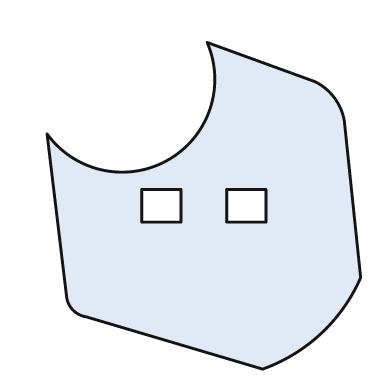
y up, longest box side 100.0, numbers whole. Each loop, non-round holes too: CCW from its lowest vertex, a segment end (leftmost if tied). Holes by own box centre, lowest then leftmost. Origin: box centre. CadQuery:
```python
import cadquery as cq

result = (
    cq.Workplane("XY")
    .moveTo(18.0, -50.0)
    .threePointArc((36.0, -39.0), (48.0, -22.0))
    .lineTo(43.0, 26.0)
    .threePointArc((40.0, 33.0), (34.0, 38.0))
    .lineTo(1.0, 50.0)
    .threePointArc((-11.0, 14.0), (-48.0, 22.0))
    .lineTo(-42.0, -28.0)
    .threePointArc((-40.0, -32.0), (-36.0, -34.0))
    .close()
    .moveTo(-19.0, -5.0)
    .lineTo(-7.0, -5.0)
    .lineTo(-7.0, 5.0)
    .lineTo(-19.0, 5.0)
    .close()
    .moveTo(7.0, -5.0)
    .lineTo(19.0, -5.0)
    .lineTo(19.0, 5.0)
    .lineTo(7.0, 5.0)
    .close()
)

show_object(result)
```